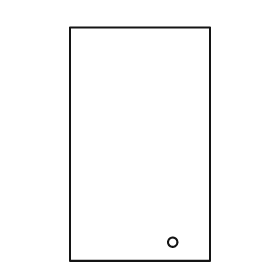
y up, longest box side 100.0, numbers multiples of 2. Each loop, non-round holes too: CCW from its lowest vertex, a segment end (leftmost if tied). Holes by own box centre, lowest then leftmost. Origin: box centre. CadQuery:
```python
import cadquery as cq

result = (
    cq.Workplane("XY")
    .moveTo(-30.0, -50.0)
    .lineTo(30.0, -50.0)
    .lineTo(30.0, 50.0)
    .lineTo(-30.0, 50.0)
    .close()
    .moveTo(14.0, -42.0)
    .circle(2.0)
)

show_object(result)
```